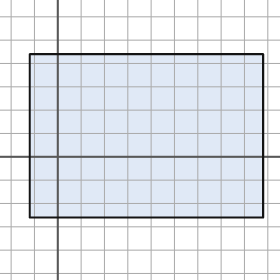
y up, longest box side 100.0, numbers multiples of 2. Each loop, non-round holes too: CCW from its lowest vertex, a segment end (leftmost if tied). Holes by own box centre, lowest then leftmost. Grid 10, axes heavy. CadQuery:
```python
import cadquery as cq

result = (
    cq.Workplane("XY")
    .moveTo(-12.0, -26.0)
    .lineTo(88.0, -26.0)
    .lineTo(88.0, 44.0)
    .lineTo(-12.0, 44.0)
    .close()
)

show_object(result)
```